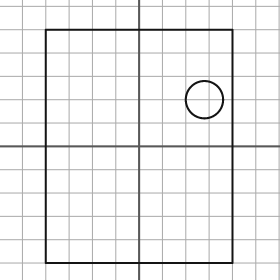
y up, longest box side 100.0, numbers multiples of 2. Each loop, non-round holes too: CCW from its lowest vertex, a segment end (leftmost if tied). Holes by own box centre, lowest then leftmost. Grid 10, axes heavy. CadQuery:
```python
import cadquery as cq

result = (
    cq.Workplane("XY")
    .moveTo(-40.0, -50.0)
    .lineTo(40.0, -50.0)
    .lineTo(40.0, 50.0)
    .lineTo(-40.0, 50.0)
    .close()
    .moveTo(28.0, 20.0)
    .circle(8.0)
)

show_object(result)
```